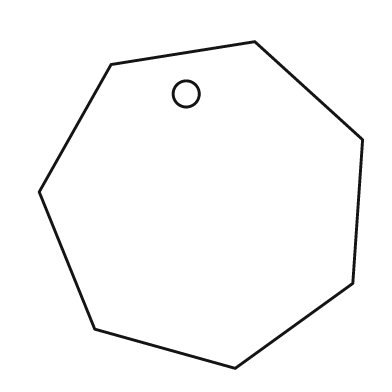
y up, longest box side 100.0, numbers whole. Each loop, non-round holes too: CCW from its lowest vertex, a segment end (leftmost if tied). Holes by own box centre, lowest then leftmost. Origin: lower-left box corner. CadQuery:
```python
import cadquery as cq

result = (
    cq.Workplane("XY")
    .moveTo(60.0, 0.0)
    .lineTo(96.0, 26.0)
    .lineTo(99.0, 70.0)
    .lineTo(66.0, 100.0)
    .lineTo(22.0, 93.0)
    .lineTo(0.0, 54.0)
    .lineTo(17.0, 12.0)
    .close()
    .moveTo(45.0, 84.0)
    .circle(4.0)
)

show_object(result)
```